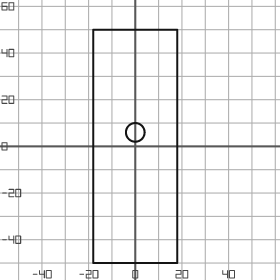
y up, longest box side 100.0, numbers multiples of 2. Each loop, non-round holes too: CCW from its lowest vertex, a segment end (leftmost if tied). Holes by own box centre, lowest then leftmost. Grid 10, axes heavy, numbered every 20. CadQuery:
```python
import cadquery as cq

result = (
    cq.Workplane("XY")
    .moveTo(-18.0, -50.0)
    .lineTo(18.0, -50.0)
    .lineTo(18.0, 50.0)
    .lineTo(-18.0, 50.0)
    .close()
    .moveTo(0.0, 6.0)
    .circle(4.0)
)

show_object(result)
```